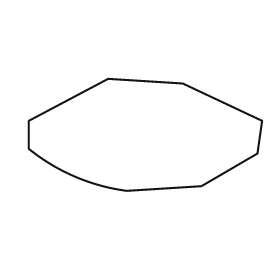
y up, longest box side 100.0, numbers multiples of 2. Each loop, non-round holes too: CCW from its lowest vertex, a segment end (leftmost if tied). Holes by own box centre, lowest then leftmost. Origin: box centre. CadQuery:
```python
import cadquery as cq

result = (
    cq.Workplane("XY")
    .moveTo(-8.0, -24.0)
    .lineTo(24.0, -22.0)
    .lineTo(48.0, -8.0)
    .lineTo(50.0, 6.0)
    .lineTo(16.0, 22.0)
    .lineTo(-16.0, 24.0)
    .lineTo(-50.0, 6.0)
    .lineTo(-50.0, -6.0)
    .threePointArc((-30.0, -18.0), (-8.0, -24.0))
    .close()
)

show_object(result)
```